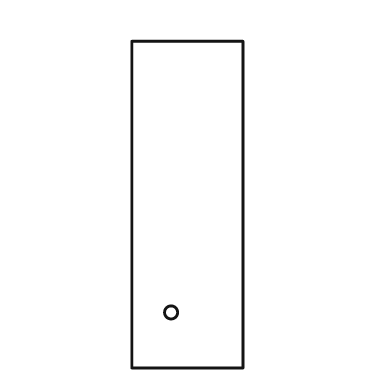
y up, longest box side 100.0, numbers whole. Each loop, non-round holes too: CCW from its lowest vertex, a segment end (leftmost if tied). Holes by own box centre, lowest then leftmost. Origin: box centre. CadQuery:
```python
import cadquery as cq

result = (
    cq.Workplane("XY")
    .moveTo(-17.0, -50.0)
    .lineTo(17.0, -50.0)
    .lineTo(17.0, 50.0)
    .lineTo(-17.0, 50.0)
    .close()
    .moveTo(-5.0, -33.0)
    .circle(2.0)
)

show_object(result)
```